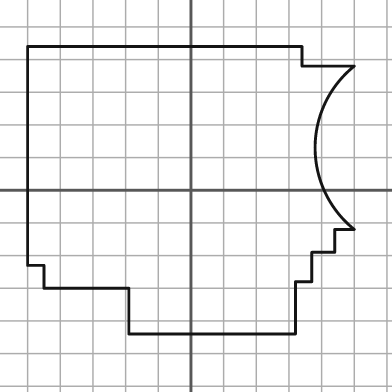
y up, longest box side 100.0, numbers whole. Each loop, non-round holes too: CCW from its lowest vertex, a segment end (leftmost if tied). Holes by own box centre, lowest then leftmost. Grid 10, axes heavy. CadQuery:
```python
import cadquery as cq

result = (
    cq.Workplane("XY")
    .moveTo(-19.0, -44.0)
    .lineTo(32.0, -44.0)
    .lineTo(32.0, -28.0)
    .lineTo(37.0, -28.0)
    .lineTo(37.0, -19.0)
    .lineTo(44.0, -19.0)
    .lineTo(44.0, -12.0)
    .lineTo(50.0, -12.0)
    .threePointArc((38.0, 13.0), (50.0, 38.0))
    .lineTo(34.0, 38.0)
    .lineTo(34.0, 44.0)
    .lineTo(-50.0, 44.0)
    .lineTo(-50.0, -23.0)
    .lineTo(-45.0, -23.0)
    .lineTo(-45.0, -30.0)
    .lineTo(-19.0, -30.0)
    .close()
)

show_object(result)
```